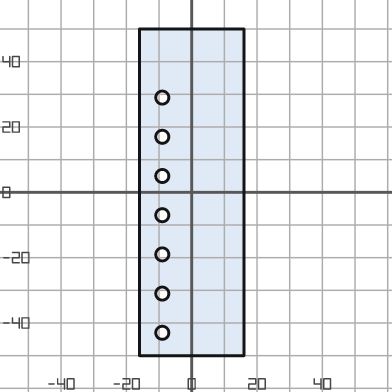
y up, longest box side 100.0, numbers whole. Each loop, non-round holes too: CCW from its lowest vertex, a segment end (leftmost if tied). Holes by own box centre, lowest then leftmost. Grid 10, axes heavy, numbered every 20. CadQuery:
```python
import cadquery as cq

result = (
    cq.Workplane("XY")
    .moveTo(-16.0, -50.0)
    .lineTo(16.0, -50.0)
    .lineTo(16.0, 50.0)
    .lineTo(-16.0, 50.0)
    .close()
    .moveTo(-9.0, -43.0)
    .circle(2.0)
    .moveTo(-9.0, -31.0)
    .circle(2.0)
    .moveTo(-9.0, -19.0)
    .circle(2.0)
    .moveTo(-9.0, -7.0)
    .circle(2.0)
    .moveTo(-9.0, 5.0)
    .circle(2.0)
    .moveTo(-9.0, 17.0)
    .circle(2.0)
    .moveTo(-9.0, 29.0)
    .circle(2.0)
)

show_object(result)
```